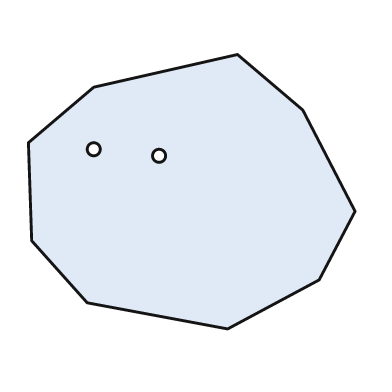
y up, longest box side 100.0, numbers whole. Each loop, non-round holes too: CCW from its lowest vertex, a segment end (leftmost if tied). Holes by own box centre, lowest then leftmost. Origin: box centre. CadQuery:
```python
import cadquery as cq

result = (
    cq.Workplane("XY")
    .moveTo(11.0, -42.0)
    .lineTo(39.0, -27.0)
    .lineTo(50.0, -6.0)
    .lineTo(34.0, 25.0)
    .lineTo(14.0, 42.0)
    .lineTo(-30.0, 32.0)
    .lineTo(-50.0, 15.0)
    .lineTo(-49.0, -15.0)
    .lineTo(-32.0, -34.0)
    .close()
    .moveTo(-10.0, 11.0)
    .circle(2.0)
    .moveTo(-30.0, 13.0)
    .circle(2.0)
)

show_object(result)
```